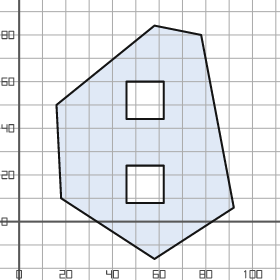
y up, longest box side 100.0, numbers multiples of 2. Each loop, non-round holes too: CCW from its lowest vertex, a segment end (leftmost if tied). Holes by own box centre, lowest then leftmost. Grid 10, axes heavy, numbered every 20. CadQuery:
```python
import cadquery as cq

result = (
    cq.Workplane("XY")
    .moveTo(58.0, -16.0)
    .lineTo(92.0, 6.0)
    .lineTo(78.0, 80.0)
    .lineTo(58.0, 84.0)
    .lineTo(16.0, 50.0)
    .lineTo(18.0, 10.0)
    .close()
    .moveTo(46.0, 8.0)
    .lineTo(62.0, 8.0)
    .lineTo(62.0, 24.0)
    .lineTo(46.0, 24.0)
    .close()
    .moveTo(46.0, 44.0)
    .lineTo(62.0, 44.0)
    .lineTo(62.0, 60.0)
    .lineTo(46.0, 60.0)
    .close()
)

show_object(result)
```